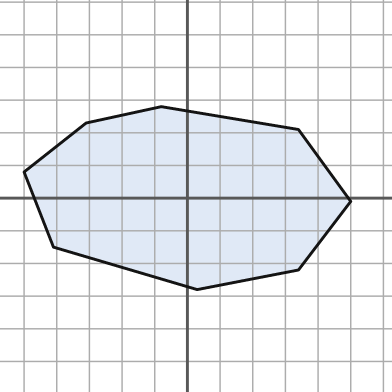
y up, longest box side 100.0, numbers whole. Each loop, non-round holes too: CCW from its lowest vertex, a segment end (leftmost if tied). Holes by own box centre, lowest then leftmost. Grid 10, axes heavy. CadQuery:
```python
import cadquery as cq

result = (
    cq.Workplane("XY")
    .moveTo(3.0, -28.0)
    .lineTo(34.0, -22.0)
    .lineTo(50.0, -1.0)
    .lineTo(34.0, 21.0)
    .lineTo(-8.0, 28.0)
    .lineTo(-31.0, 23.0)
    .lineTo(-50.0, 8.0)
    .lineTo(-41.0, -15.0)
    .close()
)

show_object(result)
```